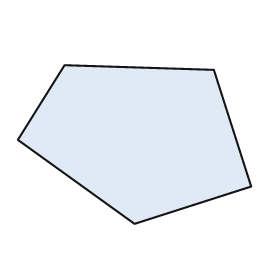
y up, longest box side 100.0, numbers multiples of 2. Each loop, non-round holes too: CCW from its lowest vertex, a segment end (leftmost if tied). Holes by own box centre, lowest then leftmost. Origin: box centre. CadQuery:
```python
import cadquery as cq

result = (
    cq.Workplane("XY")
    .moveTo(0.0, -34.0)
    .lineTo(50.0, -18.0)
    .lineTo(34.0, 32.0)
    .lineTo(-30.0, 34.0)
    .lineTo(-50.0, 2.0)
    .close()
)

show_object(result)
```